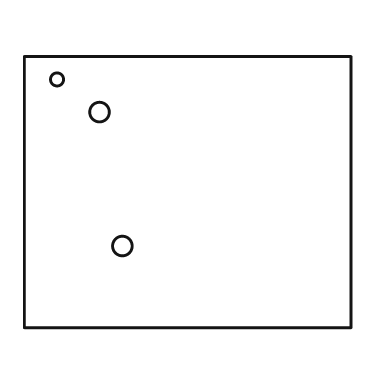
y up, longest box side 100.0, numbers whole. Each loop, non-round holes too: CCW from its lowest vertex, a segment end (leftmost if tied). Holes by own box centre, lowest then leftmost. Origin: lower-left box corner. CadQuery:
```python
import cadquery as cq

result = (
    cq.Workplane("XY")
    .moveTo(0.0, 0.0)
    .lineTo(100.0, 0.0)
    .lineTo(100.0, 83.0)
    .lineTo(0.0, 83.0)
    .close()
    .moveTo(30.0, 25.0)
    .circle(3.0)
    .moveTo(23.0, 66.0)
    .circle(3.0)
    .moveTo(10.0, 76.0)
    .circle(2.0)
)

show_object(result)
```